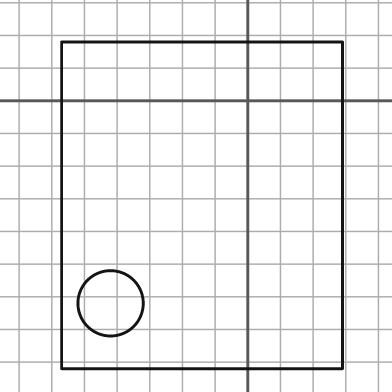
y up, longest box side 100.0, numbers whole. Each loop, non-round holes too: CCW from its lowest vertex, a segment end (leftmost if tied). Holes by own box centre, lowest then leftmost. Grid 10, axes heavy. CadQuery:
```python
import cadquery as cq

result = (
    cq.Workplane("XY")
    .moveTo(-57.0, -82.0)
    .lineTo(29.0, -82.0)
    .lineTo(29.0, 18.0)
    .lineTo(-57.0, 18.0)
    .close()
    .moveTo(-42.0, -62.0)
    .circle(10.0)
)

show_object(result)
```